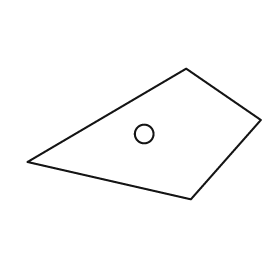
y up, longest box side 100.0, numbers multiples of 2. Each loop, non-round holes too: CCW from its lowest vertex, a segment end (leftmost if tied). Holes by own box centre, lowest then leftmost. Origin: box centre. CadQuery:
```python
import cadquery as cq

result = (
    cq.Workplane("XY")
    .moveTo(20.0, -28.0)
    .lineTo(50.0, 6.0)
    .lineTo(18.0, 28.0)
    .lineTo(-50.0, -12.0)
    .close()
    .moveTo(0.0, 0.0)
    .circle(4.0)
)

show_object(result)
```